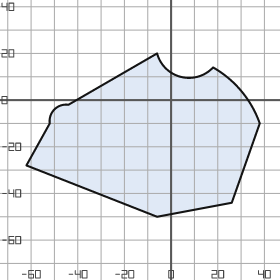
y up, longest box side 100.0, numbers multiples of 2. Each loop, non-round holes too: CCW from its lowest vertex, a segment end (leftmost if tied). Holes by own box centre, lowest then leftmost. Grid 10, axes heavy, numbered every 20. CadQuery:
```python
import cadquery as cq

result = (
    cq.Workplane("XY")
    .moveTo(-6.0, -50.0)
    .lineTo(26.0, -44.0)
    .lineTo(38.0, -10.0)
    .threePointArc((30.0, 4.0), (18.0, 14.0))
    .threePointArc((4.0, 10.0), (-6.0, 20.0))
    .lineTo(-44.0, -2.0)
    .threePointArc((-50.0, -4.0), (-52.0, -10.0))
    .lineTo(-62.0, -28.0)
    .close()
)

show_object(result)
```